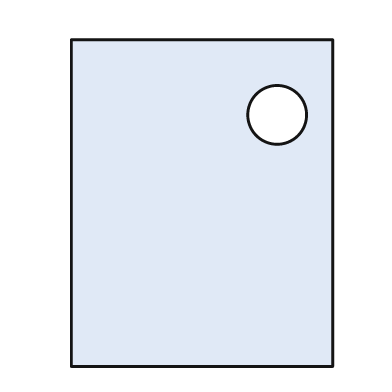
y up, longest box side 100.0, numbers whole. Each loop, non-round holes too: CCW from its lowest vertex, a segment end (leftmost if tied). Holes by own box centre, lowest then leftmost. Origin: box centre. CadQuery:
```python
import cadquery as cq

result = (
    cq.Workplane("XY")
    .moveTo(-40.0, -50.0)
    .lineTo(40.0, -50.0)
    .lineTo(40.0, 50.0)
    .lineTo(-40.0, 50.0)
    .close()
    .moveTo(23.0, 27.0)
    .circle(9.0)
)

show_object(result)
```